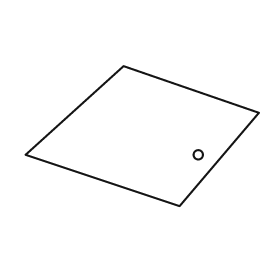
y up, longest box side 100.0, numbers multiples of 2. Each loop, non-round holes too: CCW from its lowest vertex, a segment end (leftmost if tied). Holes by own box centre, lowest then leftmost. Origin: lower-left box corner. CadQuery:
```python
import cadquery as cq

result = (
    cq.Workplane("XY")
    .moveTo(66.0, 0.0)
    .lineTo(100.0, 40.0)
    .lineTo(42.0, 60.0)
    .lineTo(0.0, 22.0)
    .close()
    .moveTo(74.0, 22.0)
    .circle(2.0)
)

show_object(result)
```